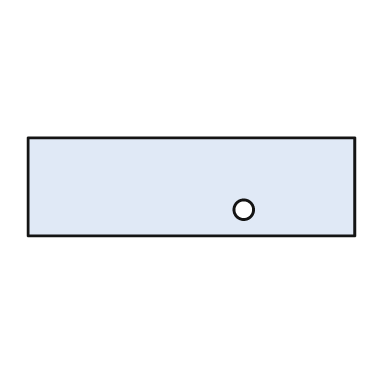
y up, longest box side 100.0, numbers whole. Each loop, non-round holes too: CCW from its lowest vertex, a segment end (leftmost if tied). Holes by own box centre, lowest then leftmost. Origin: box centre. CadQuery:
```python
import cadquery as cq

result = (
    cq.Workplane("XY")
    .moveTo(-50.0, -15.0)
    .lineTo(50.0, -15.0)
    .lineTo(50.0, 15.0)
    .lineTo(-50.0, 15.0)
    .close()
    .moveTo(16.0, -7.0)
    .circle(3.0)
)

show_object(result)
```